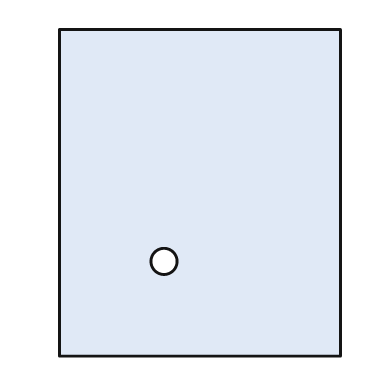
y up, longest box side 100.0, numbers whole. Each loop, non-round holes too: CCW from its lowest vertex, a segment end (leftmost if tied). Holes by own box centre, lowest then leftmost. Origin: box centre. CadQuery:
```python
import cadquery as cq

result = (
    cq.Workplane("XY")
    .moveTo(-43.0, -50.0)
    .lineTo(43.0, -50.0)
    .lineTo(43.0, 50.0)
    .lineTo(-43.0, 50.0)
    .close()
    .moveTo(-11.0, -21.0)
    .circle(4.0)
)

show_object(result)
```